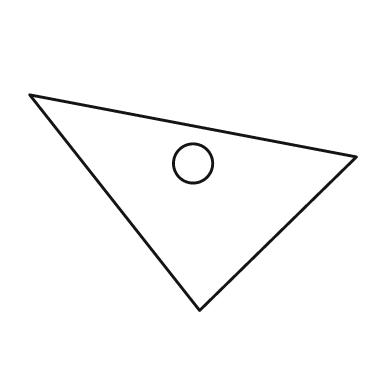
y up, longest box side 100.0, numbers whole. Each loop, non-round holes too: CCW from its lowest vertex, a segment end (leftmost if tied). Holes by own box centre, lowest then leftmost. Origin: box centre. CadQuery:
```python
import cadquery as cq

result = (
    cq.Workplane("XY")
    .moveTo(2.0, -33.0)
    .lineTo(50.0, 14.0)
    .lineTo(-50.0, 33.0)
    .close()
    .moveTo(0.0, 12.0)
    .circle(6.0)
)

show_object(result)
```